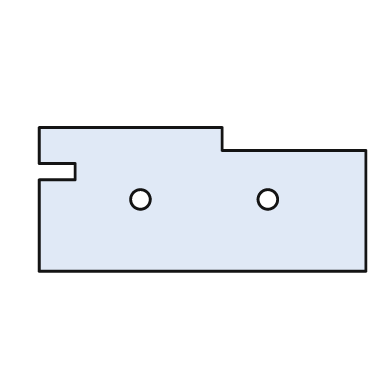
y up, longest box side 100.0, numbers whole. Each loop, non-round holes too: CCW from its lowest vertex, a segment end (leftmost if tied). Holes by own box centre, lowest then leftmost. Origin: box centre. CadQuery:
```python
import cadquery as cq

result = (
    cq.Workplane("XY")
    .moveTo(-50.0, -22.0)
    .lineTo(50.0, -22.0)
    .lineTo(50.0, 15.0)
    .lineTo(6.0, 15.0)
    .lineTo(6.0, 22.0)
    .lineTo(-50.0, 22.0)
    .lineTo(-50.0, 11.0)
    .lineTo(-39.0, 11.0)
    .lineTo(-39.0, 6.0)
    .lineTo(-50.0, 6.0)
    .close()
    .moveTo(-19.0, 0.0)
    .circle(3.0)
    .moveTo(20.0, 0.0)
    .circle(3.0)
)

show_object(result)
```